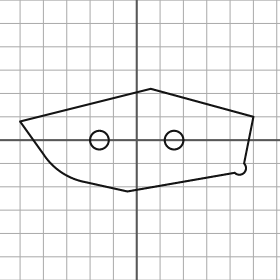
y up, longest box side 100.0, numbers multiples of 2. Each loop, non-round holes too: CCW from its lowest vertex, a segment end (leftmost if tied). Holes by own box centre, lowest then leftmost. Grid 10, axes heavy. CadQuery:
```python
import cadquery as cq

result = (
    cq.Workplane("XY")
    .moveTo(-4.0, -22.0)
    .lineTo(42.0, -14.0)
    .threePointArc((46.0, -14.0), (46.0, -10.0))
    .lineTo(50.0, 10.0)
    .lineTo(6.0, 22.0)
    .lineTo(-50.0, 8.0)
    .lineTo(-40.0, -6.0)
    .threePointArc((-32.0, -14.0), (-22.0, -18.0))
    .close()
    .moveTo(-16.0, 0.0)
    .circle(4.0)
    .moveTo(16.0, 0.0)
    .circle(4.0)
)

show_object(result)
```